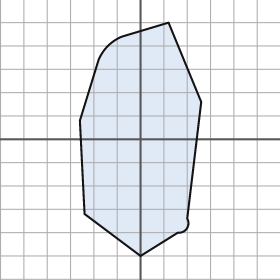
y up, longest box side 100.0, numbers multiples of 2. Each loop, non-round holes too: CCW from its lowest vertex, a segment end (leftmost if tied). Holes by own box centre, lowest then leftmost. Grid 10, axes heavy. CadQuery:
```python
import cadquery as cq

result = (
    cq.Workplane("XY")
    .moveTo(0.0, -50.0)
    .lineTo(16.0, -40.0)
    .threePointArc((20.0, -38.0), (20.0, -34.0))
    .lineTo(26.0, 16.0)
    .lineTo(12.0, 50.0)
    .lineTo(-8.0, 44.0)
    .threePointArc((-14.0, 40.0), (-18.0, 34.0))
    .lineTo(-26.0, 8.0)
    .lineTo(-24.0, -32.0)
    .close()
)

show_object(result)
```